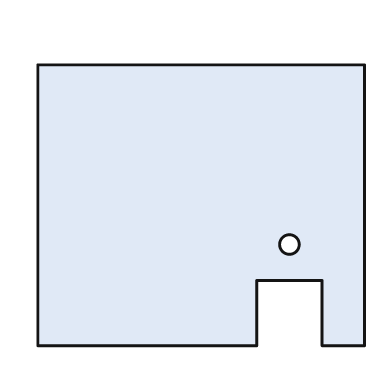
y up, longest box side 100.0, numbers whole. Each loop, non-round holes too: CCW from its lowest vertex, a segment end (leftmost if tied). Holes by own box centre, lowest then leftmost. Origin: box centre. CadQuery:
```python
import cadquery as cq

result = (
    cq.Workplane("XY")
    .moveTo(-50.0, -43.0)
    .lineTo(17.0, -43.0)
    .lineTo(17.0, -23.0)
    .lineTo(37.0, -23.0)
    .lineTo(37.0, -43.0)
    .lineTo(50.0, -43.0)
    .lineTo(50.0, 43.0)
    .lineTo(-50.0, 43.0)
    .close()
    .moveTo(27.0, -12.0)
    .circle(3.0)
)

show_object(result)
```